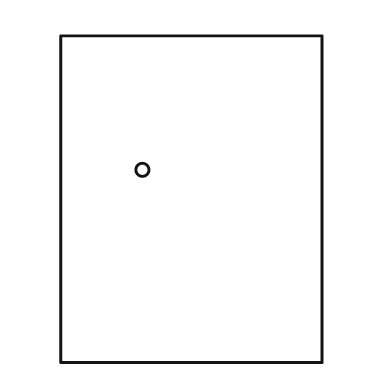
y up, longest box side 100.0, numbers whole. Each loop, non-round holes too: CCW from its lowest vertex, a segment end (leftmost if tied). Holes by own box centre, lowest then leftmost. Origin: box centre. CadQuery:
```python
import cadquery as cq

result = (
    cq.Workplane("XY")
    .moveTo(-40.0, -50.0)
    .lineTo(40.0, -50.0)
    .lineTo(40.0, 50.0)
    .lineTo(-40.0, 50.0)
    .close()
    .moveTo(-15.0, 9.0)
    .circle(2.0)
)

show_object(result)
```